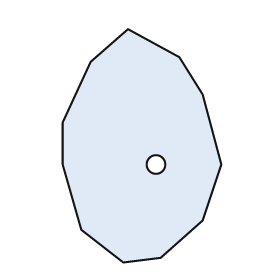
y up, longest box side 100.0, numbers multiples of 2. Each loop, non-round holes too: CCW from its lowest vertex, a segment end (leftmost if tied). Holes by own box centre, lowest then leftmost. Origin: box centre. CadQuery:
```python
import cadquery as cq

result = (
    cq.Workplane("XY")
    .moveTo(-8.0, -50.0)
    .lineTo(8.0, -48.0)
    .lineTo(26.0, -32.0)
    .lineTo(34.0, -8.0)
    .lineTo(26.0, 22.0)
    .lineTo(16.0, 38.0)
    .lineTo(-6.0, 50.0)
    .lineTo(-22.0, 36.0)
    .lineTo(-34.0, 10.0)
    .lineTo(-34.0, -8.0)
    .lineTo(-26.0, -36.0)
    .close()
    .moveTo(6.0, -8.0)
    .circle(4.0)
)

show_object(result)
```